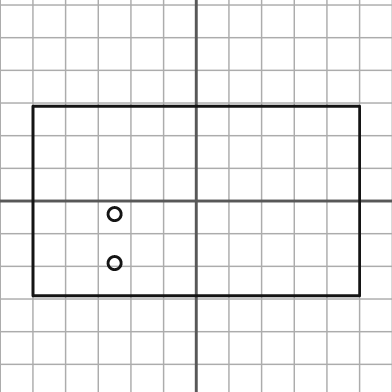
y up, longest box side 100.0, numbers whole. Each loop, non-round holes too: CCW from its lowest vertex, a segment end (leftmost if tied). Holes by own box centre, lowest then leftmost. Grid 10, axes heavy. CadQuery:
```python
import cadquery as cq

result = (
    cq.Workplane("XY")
    .moveTo(-50.0, -29.0)
    .lineTo(50.0, -29.0)
    .lineTo(50.0, 29.0)
    .lineTo(-50.0, 29.0)
    .close()
    .moveTo(-25.0, -19.0)
    .circle(2.0)
    .moveTo(-25.0, -4.0)
    .circle(2.0)
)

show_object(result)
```